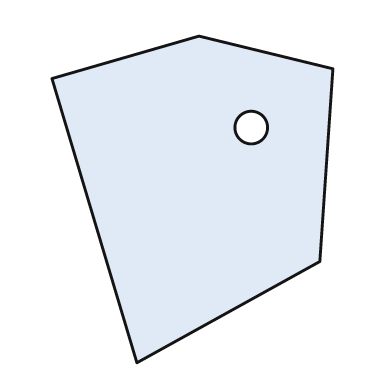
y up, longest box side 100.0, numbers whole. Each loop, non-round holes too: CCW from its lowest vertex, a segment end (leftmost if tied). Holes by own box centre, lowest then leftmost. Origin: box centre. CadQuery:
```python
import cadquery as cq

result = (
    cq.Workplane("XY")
    .moveTo(-17.0, -50.0)
    .lineTo(39.0, -19.0)
    .lineTo(43.0, 40.0)
    .lineTo(2.0, 50.0)
    .lineTo(-43.0, 37.0)
    .close()
    .moveTo(18.0, 22.0)
    .circle(5.0)
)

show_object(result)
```